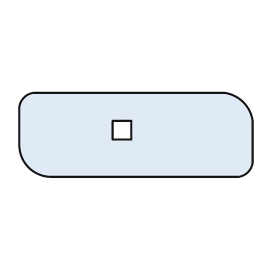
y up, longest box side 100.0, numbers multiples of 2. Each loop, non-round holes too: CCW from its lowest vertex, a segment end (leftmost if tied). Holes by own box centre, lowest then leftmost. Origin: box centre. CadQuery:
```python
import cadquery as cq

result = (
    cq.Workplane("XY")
    .moveTo(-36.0, -18.0)
    .lineTo(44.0, -18.0)
    .threePointArc((48.0, -16.0), (50.0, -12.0))
    .lineTo(50.0, 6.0)
    .threePointArc((46.0, 14.0), (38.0, 18.0))
    .lineTo(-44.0, 18.0)
    .threePointArc((-48.0, 16.0), (-50.0, 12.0))
    .lineTo(-50.0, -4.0)
    .threePointArc((-46.0, -14.0), (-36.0, -18.0))
    .close()
    .moveTo(-10.0, -2.0)
    .lineTo(-2.0, -2.0)
    .lineTo(-2.0, 6.0)
    .lineTo(-10.0, 6.0)
    .close()
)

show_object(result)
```